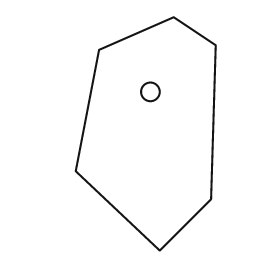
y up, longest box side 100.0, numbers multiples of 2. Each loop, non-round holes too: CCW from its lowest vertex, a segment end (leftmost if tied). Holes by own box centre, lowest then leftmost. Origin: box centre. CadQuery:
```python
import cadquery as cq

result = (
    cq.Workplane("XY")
    .moveTo(6.0, -50.0)
    .lineTo(28.0, -28.0)
    .lineTo(30.0, 38.0)
    .lineTo(12.0, 50.0)
    .lineTo(-20.0, 36.0)
    .lineTo(-30.0, -16.0)
    .close()
    .moveTo(2.0, 18.0)
    .circle(4.0)
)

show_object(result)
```